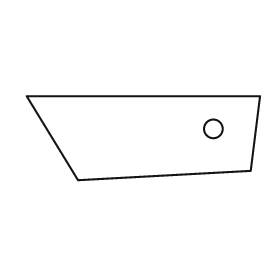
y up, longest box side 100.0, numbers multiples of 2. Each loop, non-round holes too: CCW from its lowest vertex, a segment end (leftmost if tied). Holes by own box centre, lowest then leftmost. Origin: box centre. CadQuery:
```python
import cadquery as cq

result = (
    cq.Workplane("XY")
    .moveTo(-28.0, -18.0)
    .lineTo(46.0, -14.0)
    .lineTo(50.0, 18.0)
    .lineTo(-50.0, 18.0)
    .close()
    .moveTo(30.0, 4.0)
    .circle(4.0)
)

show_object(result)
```